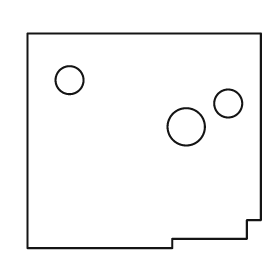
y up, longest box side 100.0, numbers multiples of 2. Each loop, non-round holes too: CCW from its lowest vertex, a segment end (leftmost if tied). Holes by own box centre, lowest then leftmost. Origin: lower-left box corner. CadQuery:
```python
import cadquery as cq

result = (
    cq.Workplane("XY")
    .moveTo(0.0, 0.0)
    .lineTo(62.0, 0.0)
    .lineTo(62.0, 4.0)
    .lineTo(94.0, 4.0)
    .lineTo(94.0, 12.0)
    .lineTo(100.0, 12.0)
    .lineTo(100.0, 92.0)
    .lineTo(0.0, 92.0)
    .close()
    .moveTo(68.0, 52.0)
    .circle(8.0)
    .moveTo(86.0, 62.0)
    .circle(6.0)
    .moveTo(18.0, 72.0)
    .circle(6.0)
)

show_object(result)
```